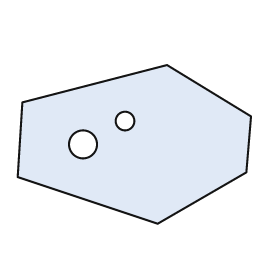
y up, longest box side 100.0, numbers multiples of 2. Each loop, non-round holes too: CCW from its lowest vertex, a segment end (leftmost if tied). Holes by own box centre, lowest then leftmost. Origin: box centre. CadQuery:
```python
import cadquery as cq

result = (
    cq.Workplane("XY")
    .moveTo(10.0, -34.0)
    .lineTo(48.0, -12.0)
    .lineTo(50.0, 12.0)
    .lineTo(14.0, 34.0)
    .lineTo(-48.0, 18.0)
    .lineTo(-50.0, -14.0)
    .close()
    .moveTo(-22.0, 0.0)
    .circle(6.0)
    .moveTo(-4.0, 10.0)
    .circle(4.0)
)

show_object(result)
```